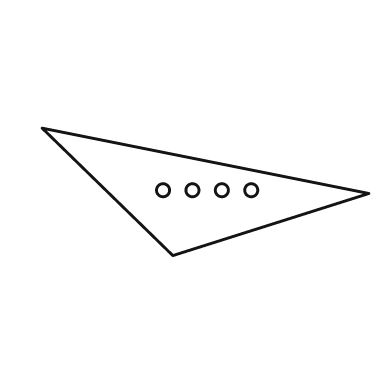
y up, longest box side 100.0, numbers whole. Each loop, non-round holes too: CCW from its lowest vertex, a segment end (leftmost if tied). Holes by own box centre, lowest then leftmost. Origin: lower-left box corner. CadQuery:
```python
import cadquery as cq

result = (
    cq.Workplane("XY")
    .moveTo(40.0, 0.0)
    .lineTo(100.0, 19.0)
    .lineTo(0.0, 39.0)
    .close()
    .moveTo(37.0, 20.0)
    .circle(2.0)
    .moveTo(46.0, 20.0)
    .circle(2.0)
    .moveTo(55.0, 20.0)
    .circle(2.0)
    .moveTo(64.0, 20.0)
    .circle(2.0)
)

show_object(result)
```